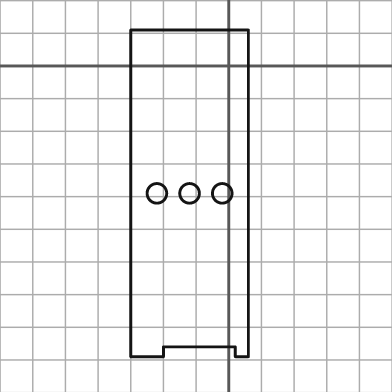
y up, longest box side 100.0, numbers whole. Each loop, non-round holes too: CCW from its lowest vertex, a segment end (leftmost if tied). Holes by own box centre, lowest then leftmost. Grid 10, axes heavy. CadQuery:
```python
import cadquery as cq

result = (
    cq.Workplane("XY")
    .moveTo(-30.0, -89.0)
    .lineTo(-20.0, -89.0)
    .lineTo(-20.0, -86.0)
    .lineTo(2.0, -86.0)
    .lineTo(2.0, -89.0)
    .lineTo(6.0, -89.0)
    .lineTo(6.0, 11.0)
    .lineTo(-30.0, 11.0)
    .close()
    .moveTo(-22.0, -39.0)
    .circle(3.0)
    .moveTo(-12.0, -39.0)
    .circle(3.0)
    .moveTo(-2.0, -39.0)
    .circle(3.0)
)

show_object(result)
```